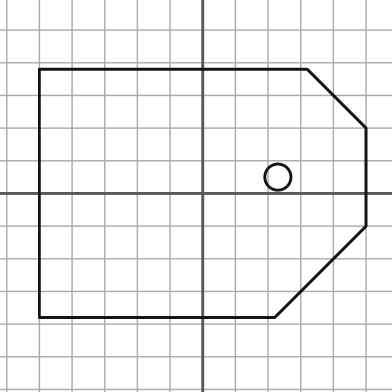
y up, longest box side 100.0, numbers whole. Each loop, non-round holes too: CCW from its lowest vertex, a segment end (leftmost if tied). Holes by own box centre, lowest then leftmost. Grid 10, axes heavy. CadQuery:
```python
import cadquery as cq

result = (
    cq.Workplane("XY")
    .moveTo(-50.0, -38.0)
    .lineTo(22.0, -38.0)
    .lineTo(50.0, -10.0)
    .lineTo(50.0, 20.0)
    .lineTo(32.0, 38.0)
    .lineTo(-50.0, 38.0)
    .close()
    .moveTo(23.0, 5.0)
    .circle(4.0)
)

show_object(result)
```